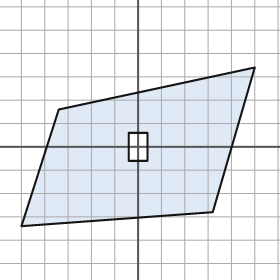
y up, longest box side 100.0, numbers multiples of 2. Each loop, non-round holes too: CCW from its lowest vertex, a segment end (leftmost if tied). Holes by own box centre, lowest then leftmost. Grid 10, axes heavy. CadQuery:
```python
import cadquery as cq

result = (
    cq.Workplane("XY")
    .moveTo(-50.0, -34.0)
    .lineTo(32.0, -28.0)
    .lineTo(50.0, 34.0)
    .lineTo(-34.0, 16.0)
    .close()
    .moveTo(-4.0, -6.0)
    .lineTo(4.0, -6.0)
    .lineTo(4.0, 6.0)
    .lineTo(-4.0, 6.0)
    .close()
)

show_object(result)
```